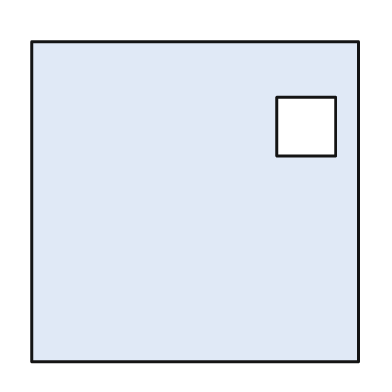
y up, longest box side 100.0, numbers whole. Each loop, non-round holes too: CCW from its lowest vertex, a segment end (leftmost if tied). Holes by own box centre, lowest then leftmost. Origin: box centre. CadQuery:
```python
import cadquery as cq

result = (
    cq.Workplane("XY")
    .moveTo(-50.0, -49.0)
    .lineTo(50.0, -49.0)
    .lineTo(50.0, 49.0)
    .lineTo(-50.0, 49.0)
    .close()
    .moveTo(25.0, 14.0)
    .lineTo(43.0, 14.0)
    .lineTo(43.0, 32.0)
    .lineTo(25.0, 32.0)
    .close()
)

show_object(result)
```